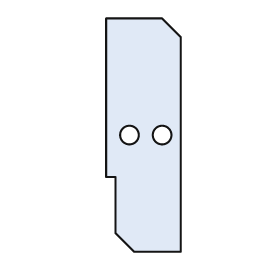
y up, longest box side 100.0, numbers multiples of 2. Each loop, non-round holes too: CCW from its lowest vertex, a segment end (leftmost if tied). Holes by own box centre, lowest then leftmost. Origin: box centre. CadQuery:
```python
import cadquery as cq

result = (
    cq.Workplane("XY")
    .moveTo(-4.0, -50.0)
    .lineTo(16.0, -50.0)
    .lineTo(16.0, 42.0)
    .lineTo(8.0, 50.0)
    .lineTo(-16.0, 50.0)
    .lineTo(-16.0, -18.0)
    .lineTo(-12.0, -18.0)
    .lineTo(-12.0, -42.0)
    .close()
    .moveTo(-6.0, 0.0)
    .circle(4.0)
    .moveTo(8.0, 0.0)
    .circle(4.0)
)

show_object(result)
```